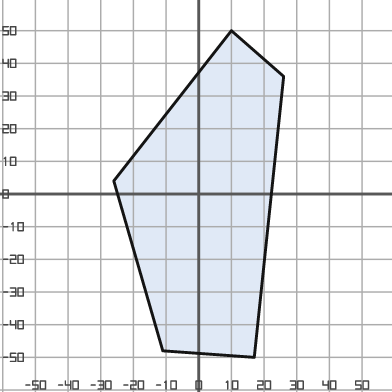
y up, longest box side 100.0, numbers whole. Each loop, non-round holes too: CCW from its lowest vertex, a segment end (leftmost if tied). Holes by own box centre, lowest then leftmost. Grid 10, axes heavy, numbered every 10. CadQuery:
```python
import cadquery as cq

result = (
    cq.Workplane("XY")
    .moveTo(17.0, -50.0)
    .lineTo(26.0, 36.0)
    .lineTo(10.0, 50.0)
    .lineTo(-26.0, 4.0)
    .lineTo(-11.0, -48.0)
    .close()
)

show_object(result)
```